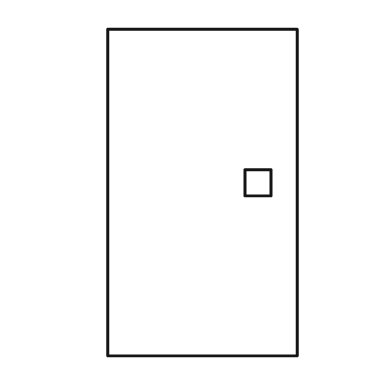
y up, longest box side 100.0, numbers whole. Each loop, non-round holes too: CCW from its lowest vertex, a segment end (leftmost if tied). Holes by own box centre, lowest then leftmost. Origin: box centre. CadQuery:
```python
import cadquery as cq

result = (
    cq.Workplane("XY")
    .moveTo(-29.0, -50.0)
    .lineTo(29.0, -50.0)
    .lineTo(29.0, 50.0)
    .lineTo(-29.0, 50.0)
    .close()
    .moveTo(13.0, -1.0)
    .lineTo(21.0, -1.0)
    .lineTo(21.0, 7.0)
    .lineTo(13.0, 7.0)
    .close()
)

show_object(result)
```